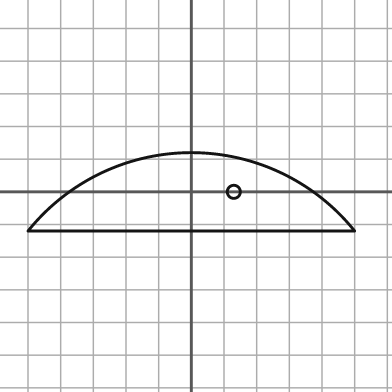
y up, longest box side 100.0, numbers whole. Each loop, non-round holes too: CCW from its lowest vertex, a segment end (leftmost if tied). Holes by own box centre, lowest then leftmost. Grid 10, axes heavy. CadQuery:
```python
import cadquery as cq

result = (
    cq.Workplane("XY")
    .moveTo(-50.0, -12.0)
    .lineTo(50.0, -12.0)
    .threePointArc((0.0, 12.0), (-50.0, -12.0))
    .close()
    .moveTo(13.0, 0.0)
    .circle(2.0)
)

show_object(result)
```